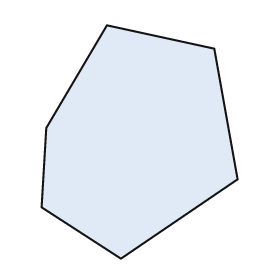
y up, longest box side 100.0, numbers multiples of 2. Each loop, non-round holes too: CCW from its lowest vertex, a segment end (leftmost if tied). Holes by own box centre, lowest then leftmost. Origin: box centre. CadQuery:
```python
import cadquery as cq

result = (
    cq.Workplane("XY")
    .moveTo(-8.0, -50.0)
    .lineTo(42.0, -16.0)
    .lineTo(32.0, 40.0)
    .lineTo(-14.0, 50.0)
    .lineTo(-40.0, 6.0)
    .lineTo(-42.0, -28.0)
    .close()
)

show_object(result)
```